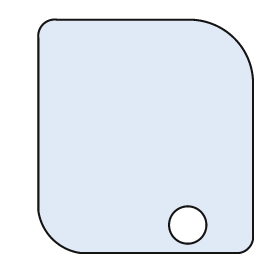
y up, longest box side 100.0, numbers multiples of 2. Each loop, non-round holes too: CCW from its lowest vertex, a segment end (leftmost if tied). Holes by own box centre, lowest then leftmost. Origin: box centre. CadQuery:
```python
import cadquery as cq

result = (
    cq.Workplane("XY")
    .moveTo(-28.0, -50.0)
    .lineTo(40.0, -50.0)
    .threePointArc((44.0, -48.0), (46.0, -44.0))
    .lineTo(46.0, 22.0)
    .threePointArc((38.0, 42.0), (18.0, 50.0))
    .lineTo(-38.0, 50.0)
    .threePointArc((-44.0, 48.0), (-46.0, 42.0))
    .lineTo(-46.0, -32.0)
    .threePointArc((-40.0, -44.0), (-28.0, -50.0))
    .close()
    .moveTo(18.0, -38.0)
    .circle(8.0)
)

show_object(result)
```